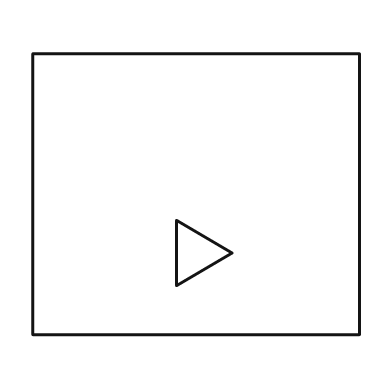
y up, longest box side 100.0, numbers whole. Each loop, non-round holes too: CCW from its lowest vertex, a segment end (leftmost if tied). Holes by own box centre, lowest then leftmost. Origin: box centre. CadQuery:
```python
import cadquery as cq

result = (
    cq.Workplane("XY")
    .moveTo(-50.0, -43.0)
    .lineTo(50.0, -43.0)
    .lineTo(50.0, 43.0)
    .lineTo(-50.0, 43.0)
    .close()
    .moveTo(-6.0, -28.0)
    .lineTo(11.0, -18.0)
    .lineTo(-6.0, -8.0)
    .close()
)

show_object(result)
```